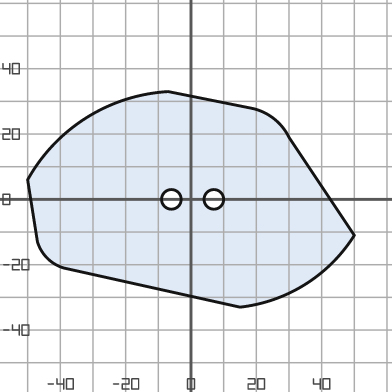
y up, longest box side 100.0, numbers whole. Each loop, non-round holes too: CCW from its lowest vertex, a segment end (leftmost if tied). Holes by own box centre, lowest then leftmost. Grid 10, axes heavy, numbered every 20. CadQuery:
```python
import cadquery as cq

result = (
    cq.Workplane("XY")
    .moveTo(15.0, -33.0)
    .threePointArc((35.0, -26.0), (50.0, -11.0))
    .lineTo(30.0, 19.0)
    .threePointArc((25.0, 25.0), (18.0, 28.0))
    .lineTo(-7.0, 33.0)
    .threePointArc((-32.0, 25.0), (-50.0, 6.0))
    .lineTo(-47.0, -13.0)
    .threePointArc((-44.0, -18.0), (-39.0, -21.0))
    .close()
    .moveTo(-6.0, 0.0)
    .circle(3.0)
    .moveTo(7.0, 0.0)
    .circle(3.0)
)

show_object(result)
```